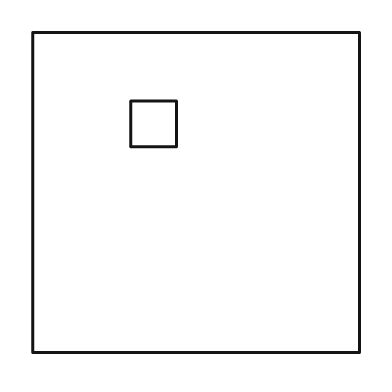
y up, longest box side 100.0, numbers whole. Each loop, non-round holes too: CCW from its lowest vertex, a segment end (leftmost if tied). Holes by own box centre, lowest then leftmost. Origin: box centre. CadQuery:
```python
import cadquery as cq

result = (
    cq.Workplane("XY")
    .moveTo(-50.0, -49.0)
    .lineTo(50.0, -49.0)
    .lineTo(50.0, 49.0)
    .lineTo(-50.0, 49.0)
    .close()
    .moveTo(-20.0, 14.0)
    .lineTo(-6.0, 14.0)
    .lineTo(-6.0, 28.0)
    .lineTo(-20.0, 28.0)
    .close()
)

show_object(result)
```